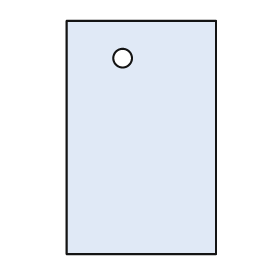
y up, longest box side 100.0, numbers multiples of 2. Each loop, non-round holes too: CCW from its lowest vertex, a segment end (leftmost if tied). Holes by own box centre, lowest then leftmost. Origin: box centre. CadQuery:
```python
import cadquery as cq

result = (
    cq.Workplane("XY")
    .moveTo(-32.0, -50.0)
    .lineTo(32.0, -50.0)
    .lineTo(32.0, 50.0)
    .lineTo(-32.0, 50.0)
    .close()
    .moveTo(-8.0, 34.0)
    .circle(4.0)
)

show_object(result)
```